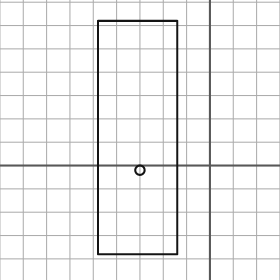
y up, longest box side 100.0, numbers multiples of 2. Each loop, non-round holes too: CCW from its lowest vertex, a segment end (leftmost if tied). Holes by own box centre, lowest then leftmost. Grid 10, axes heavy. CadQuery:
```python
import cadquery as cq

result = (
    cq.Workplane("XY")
    .moveTo(-48.0, -38.0)
    .lineTo(-14.0, -38.0)
    .lineTo(-14.0, 62.0)
    .lineTo(-48.0, 62.0)
    .close()
    .moveTo(-30.0, -2.0)
    .circle(2.0)
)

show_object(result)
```